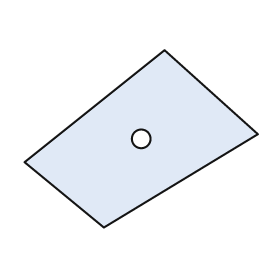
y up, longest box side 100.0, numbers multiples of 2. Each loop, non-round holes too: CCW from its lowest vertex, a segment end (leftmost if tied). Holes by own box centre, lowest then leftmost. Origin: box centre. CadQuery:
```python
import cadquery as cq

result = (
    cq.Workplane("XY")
    .moveTo(-16.0, -38.0)
    .lineTo(50.0, 2.0)
    .lineTo(10.0, 38.0)
    .lineTo(-50.0, -10.0)
    .close()
    .moveTo(0.0, 0.0)
    .circle(4.0)
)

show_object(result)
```